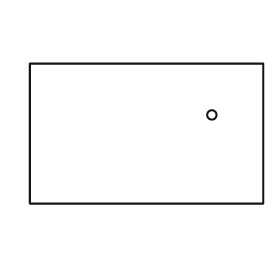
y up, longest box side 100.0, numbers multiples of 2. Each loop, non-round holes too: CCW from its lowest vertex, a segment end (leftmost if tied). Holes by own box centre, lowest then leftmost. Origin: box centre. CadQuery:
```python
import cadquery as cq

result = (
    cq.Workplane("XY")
    .moveTo(-50.0, -30.0)
    .lineTo(50.0, -30.0)
    .lineTo(50.0, 30.0)
    .lineTo(-50.0, 30.0)
    .close()
    .moveTo(28.0, 8.0)
    .circle(2.0)
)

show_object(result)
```